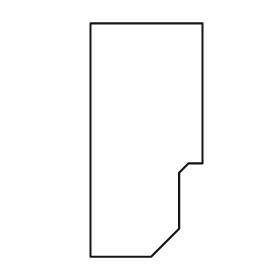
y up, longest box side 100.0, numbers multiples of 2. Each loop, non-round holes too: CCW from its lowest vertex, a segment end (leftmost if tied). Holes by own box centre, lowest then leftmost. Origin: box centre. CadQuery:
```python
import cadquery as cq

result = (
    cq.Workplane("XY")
    .moveTo(-24.0, -50.0)
    .lineTo(2.0, -50.0)
    .lineTo(14.0, -38.0)
    .lineTo(14.0, -14.0)
    .lineTo(18.0, -10.0)
    .lineTo(24.0, -10.0)
    .lineTo(24.0, 50.0)
    .lineTo(-24.0, 50.0)
    .close()
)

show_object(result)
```